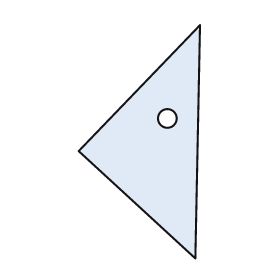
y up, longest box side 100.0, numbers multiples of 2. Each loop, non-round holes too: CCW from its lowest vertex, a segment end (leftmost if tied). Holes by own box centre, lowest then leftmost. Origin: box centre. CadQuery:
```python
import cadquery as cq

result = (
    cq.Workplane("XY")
    .moveTo(24.0, -50.0)
    .lineTo(26.0, 50.0)
    .lineTo(-26.0, -4.0)
    .close()
    .moveTo(12.0, 10.0)
    .circle(4.0)
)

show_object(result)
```